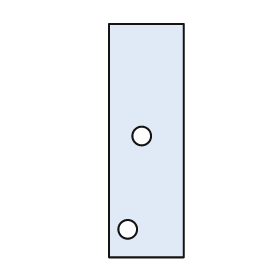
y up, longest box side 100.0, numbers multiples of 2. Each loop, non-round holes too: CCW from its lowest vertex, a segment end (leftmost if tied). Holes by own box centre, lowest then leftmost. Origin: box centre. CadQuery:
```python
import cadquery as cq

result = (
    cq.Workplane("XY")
    .moveTo(-16.0, -50.0)
    .lineTo(16.0, -50.0)
    .lineTo(16.0, 50.0)
    .lineTo(-16.0, 50.0)
    .close()
    .moveTo(-8.0, -38.0)
    .circle(4.0)
    .moveTo(-2.0, 2.0)
    .circle(4.0)
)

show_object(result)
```